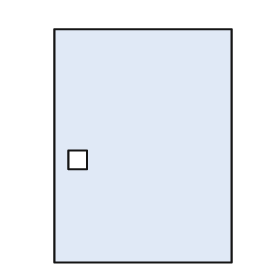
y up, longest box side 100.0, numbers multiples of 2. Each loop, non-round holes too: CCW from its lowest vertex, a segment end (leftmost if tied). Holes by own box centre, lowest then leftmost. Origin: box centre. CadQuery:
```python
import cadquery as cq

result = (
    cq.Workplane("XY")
    .moveTo(-38.0, -50.0)
    .lineTo(38.0, -50.0)
    .lineTo(38.0, 50.0)
    .lineTo(-38.0, 50.0)
    .close()
    .moveTo(-32.0, -10.0)
    .lineTo(-24.0, -10.0)
    .lineTo(-24.0, -2.0)
    .lineTo(-32.0, -2.0)
    .close()
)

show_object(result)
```